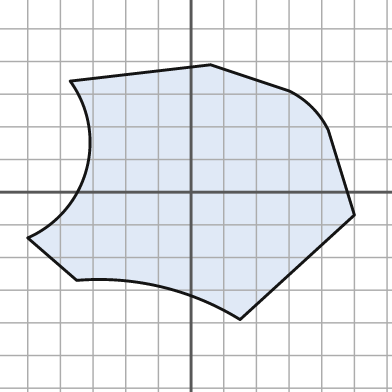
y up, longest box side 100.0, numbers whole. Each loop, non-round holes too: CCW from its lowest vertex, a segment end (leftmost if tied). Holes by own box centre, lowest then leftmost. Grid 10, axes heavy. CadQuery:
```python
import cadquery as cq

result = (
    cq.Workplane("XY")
    .moveTo(15.0, -39.0)
    .lineTo(50.0, -7.0)
    .lineTo(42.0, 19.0)
    .threePointArc((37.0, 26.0), (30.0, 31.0))
    .lineTo(6.0, 39.0)
    .lineTo(-37.0, 34.0)
    .threePointArc((-32.0, 7.0), (-50.0, -14.0))
    .lineTo(-35.0, -27.0)
    .threePointArc((-9.0, -29.0), (15.0, -39.0))
    .close()
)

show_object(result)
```